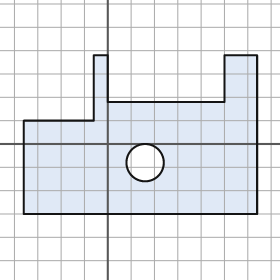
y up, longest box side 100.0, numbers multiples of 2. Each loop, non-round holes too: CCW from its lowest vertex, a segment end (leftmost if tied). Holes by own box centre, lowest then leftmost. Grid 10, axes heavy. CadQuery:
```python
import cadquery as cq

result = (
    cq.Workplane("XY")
    .moveTo(-36.0, -30.0)
    .lineTo(64.0, -30.0)
    .lineTo(64.0, 38.0)
    .lineTo(50.0, 38.0)
    .lineTo(50.0, 18.0)
    .lineTo(0.0, 18.0)
    .lineTo(0.0, 38.0)
    .lineTo(-6.0, 38.0)
    .lineTo(-6.0, 10.0)
    .lineTo(-36.0, 10.0)
    .close()
    .moveTo(16.0, -8.0)
    .circle(8.0)
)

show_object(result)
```